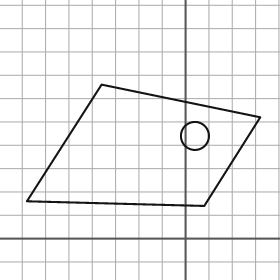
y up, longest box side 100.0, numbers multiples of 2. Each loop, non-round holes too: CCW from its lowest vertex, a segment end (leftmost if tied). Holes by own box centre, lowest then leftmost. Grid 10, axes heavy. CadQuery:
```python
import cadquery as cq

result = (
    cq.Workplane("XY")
    .moveTo(8.0, 14.0)
    .lineTo(32.0, 52.0)
    .lineTo(-36.0, 66.0)
    .lineTo(-68.0, 16.0)
    .close()
    .moveTo(4.0, 44.0)
    .circle(6.0)
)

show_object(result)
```